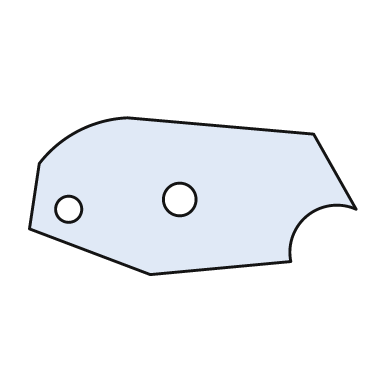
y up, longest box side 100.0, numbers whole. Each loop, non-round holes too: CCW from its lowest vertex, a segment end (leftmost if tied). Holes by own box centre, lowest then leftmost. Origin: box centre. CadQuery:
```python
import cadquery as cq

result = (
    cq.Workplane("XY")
    .moveTo(-13.0, -24.0)
    .lineTo(30.0, -20.0)
    .threePointArc((35.0, -6.0), (50.0, -4.0))
    .lineTo(37.0, 19.0)
    .lineTo(-20.0, 24.0)
    .threePointArc((-35.0, 20.0), (-47.0, 10.0))
    .lineTo(-50.0, -10.0)
    .close()
    .moveTo(-38.0, -4.0)
    .circle(4.0)
    .moveTo(-4.0, -1.0)
    .circle(5.0)
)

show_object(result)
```